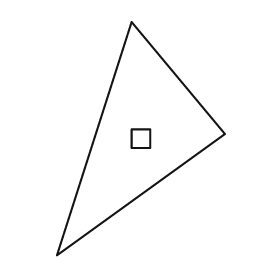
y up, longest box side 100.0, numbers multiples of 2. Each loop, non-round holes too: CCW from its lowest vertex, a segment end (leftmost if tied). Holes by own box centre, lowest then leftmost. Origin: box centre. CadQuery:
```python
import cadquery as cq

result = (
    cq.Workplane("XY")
    .moveTo(-36.0, -50.0)
    .lineTo(36.0, 2.0)
    .lineTo(-4.0, 50.0)
    .close()
    .moveTo(-4.0, -4.0)
    .lineTo(4.0, -4.0)
    .lineTo(4.0, 4.0)
    .lineTo(-4.0, 4.0)
    .close()
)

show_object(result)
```